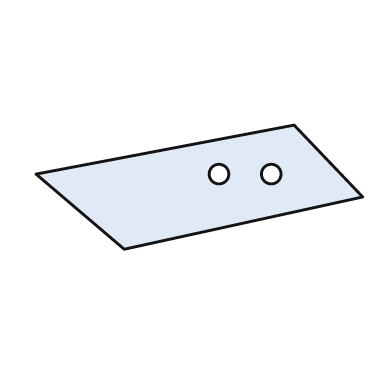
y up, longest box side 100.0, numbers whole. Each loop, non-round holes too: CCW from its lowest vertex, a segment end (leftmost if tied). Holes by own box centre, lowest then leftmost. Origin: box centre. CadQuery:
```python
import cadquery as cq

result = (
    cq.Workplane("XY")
    .moveTo(-23.0, -19.0)
    .lineTo(50.0, -3.0)
    .lineTo(29.0, 19.0)
    .lineTo(-50.0, 4.0)
    .close()
    .moveTo(6.0, 4.0)
    .circle(3.0)
    .moveTo(22.0, 4.0)
    .circle(3.0)
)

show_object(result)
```